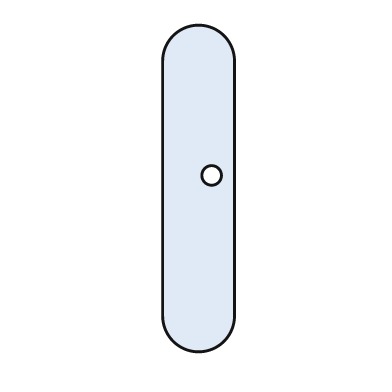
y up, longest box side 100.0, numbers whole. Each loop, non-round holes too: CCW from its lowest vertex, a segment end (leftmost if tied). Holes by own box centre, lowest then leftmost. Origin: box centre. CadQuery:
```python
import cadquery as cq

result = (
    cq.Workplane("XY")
    .moveTo(-11.0, -39.0)
    .threePointArc((0.0, -50.0), (11.0, -39.0))
    .lineTo(11.0, 39.0)
    .threePointArc((0.0, 50.0), (-11.0, 39.0))
    .close()
    .moveTo(4.0, 4.0)
    .circle(3.0)
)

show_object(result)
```